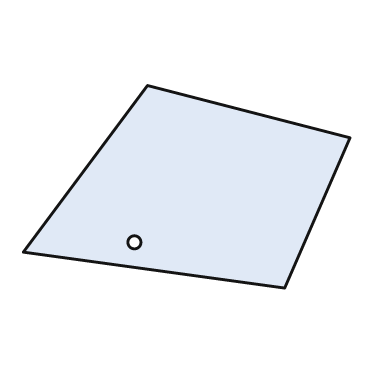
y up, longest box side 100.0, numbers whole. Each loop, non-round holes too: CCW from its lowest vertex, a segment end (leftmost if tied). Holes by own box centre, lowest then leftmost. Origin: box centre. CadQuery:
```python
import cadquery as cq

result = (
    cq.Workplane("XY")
    .moveTo(30.0, -31.0)
    .lineTo(50.0, 15.0)
    .lineTo(-12.0, 31.0)
    .lineTo(-50.0, -20.0)
    .close()
    .moveTo(-16.0, -17.0)
    .circle(2.0)
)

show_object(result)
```